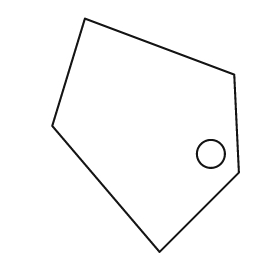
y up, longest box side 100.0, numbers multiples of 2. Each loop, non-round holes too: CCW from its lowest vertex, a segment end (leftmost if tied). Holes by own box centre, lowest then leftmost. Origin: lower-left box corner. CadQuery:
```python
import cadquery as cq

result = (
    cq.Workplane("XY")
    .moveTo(46.0, 0.0)
    .lineTo(80.0, 34.0)
    .lineTo(78.0, 76.0)
    .lineTo(14.0, 100.0)
    .lineTo(0.0, 54.0)
    .close()
    .moveTo(68.0, 42.0)
    .circle(6.0)
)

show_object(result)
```